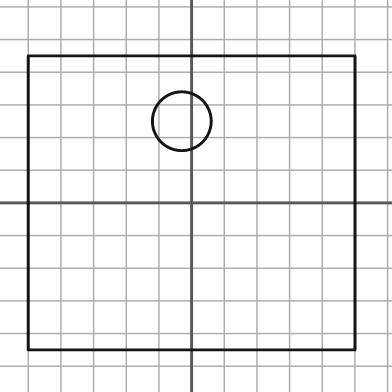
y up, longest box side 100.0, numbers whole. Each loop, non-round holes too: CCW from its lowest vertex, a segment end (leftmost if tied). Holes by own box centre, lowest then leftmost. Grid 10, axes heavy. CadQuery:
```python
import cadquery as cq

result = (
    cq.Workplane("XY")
    .moveTo(-50.0, -45.0)
    .lineTo(50.0, -45.0)
    .lineTo(50.0, 45.0)
    .lineTo(-50.0, 45.0)
    .close()
    .moveTo(-3.0, 25.0)
    .circle(9.0)
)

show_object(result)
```